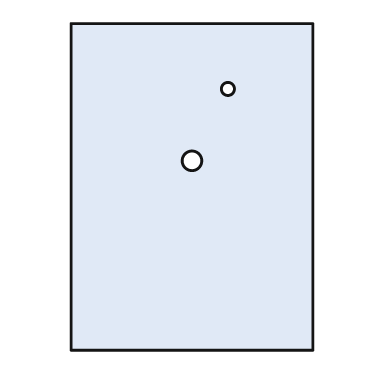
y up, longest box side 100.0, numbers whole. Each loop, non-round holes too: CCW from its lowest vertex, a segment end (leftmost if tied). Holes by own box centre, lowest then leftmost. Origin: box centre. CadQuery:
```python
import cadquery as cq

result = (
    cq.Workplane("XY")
    .moveTo(-37.0, -50.0)
    .lineTo(37.0, -50.0)
    .lineTo(37.0, 50.0)
    .lineTo(-37.0, 50.0)
    .close()
    .moveTo(0.0, 8.0)
    .circle(3.0)
    .moveTo(11.0, 30.0)
    .circle(2.0)
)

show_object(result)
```